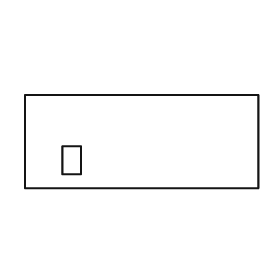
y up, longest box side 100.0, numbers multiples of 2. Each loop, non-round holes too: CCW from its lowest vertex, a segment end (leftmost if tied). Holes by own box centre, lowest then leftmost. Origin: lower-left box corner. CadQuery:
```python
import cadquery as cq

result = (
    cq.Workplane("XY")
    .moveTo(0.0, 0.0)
    .lineTo(100.0, 0.0)
    .lineTo(100.0, 40.0)
    .lineTo(0.0, 40.0)
    .close()
    .moveTo(16.0, 6.0)
    .lineTo(24.0, 6.0)
    .lineTo(24.0, 18.0)
    .lineTo(16.0, 18.0)
    .close()
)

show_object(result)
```